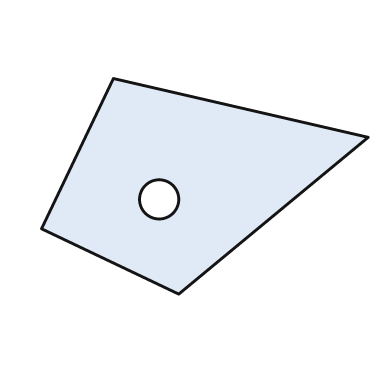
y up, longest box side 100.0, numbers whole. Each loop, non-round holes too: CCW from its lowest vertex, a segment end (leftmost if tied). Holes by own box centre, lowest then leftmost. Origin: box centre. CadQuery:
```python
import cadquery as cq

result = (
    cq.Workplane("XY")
    .moveTo(-8.0, -33.0)
    .lineTo(50.0, 15.0)
    .lineTo(-28.0, 33.0)
    .lineTo(-50.0, -13.0)
    .close()
    .moveTo(-14.0, -4.0)
    .circle(6.0)
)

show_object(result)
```